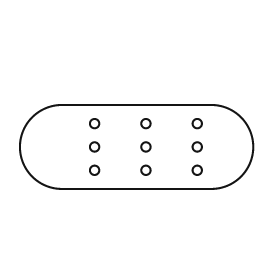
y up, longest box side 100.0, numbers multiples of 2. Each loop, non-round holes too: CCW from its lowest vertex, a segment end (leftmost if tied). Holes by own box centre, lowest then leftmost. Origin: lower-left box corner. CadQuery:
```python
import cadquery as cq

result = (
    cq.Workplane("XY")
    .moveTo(18.0, 0.0)
    .lineTo(82.0, 0.0)
    .threePointArc((100.0, 18.0), (82.0, 36.0))
    .lineTo(18.0, 36.0)
    .threePointArc((0.0, 18.0), (18.0, 0.0))
    .close()
    .moveTo(32.0, 8.0)
    .circle(2.0)
    .moveTo(54.0, 8.0)
    .circle(2.0)
    .moveTo(76.0, 8.0)
    .circle(2.0)
    .moveTo(32.0, 18.0)
    .circle(2.0)
    .moveTo(54.0, 18.0)
    .circle(2.0)
    .moveTo(76.0, 18.0)
    .circle(2.0)
    .moveTo(32.0, 28.0)
    .circle(2.0)
    .moveTo(54.0, 28.0)
    .circle(2.0)
    .moveTo(76.0, 28.0)
    .circle(2.0)
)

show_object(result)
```